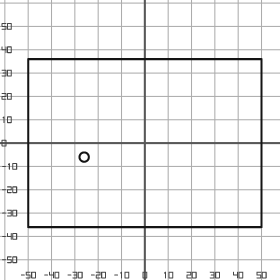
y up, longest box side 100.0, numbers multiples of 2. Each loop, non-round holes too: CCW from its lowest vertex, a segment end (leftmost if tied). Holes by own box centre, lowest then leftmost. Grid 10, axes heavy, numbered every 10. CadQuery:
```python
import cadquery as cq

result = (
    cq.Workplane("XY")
    .moveTo(-50.0, -36.0)
    .lineTo(50.0, -36.0)
    .lineTo(50.0, 36.0)
    .lineTo(-50.0, 36.0)
    .close()
    .moveTo(-26.0, -6.0)
    .circle(2.0)
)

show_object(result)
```